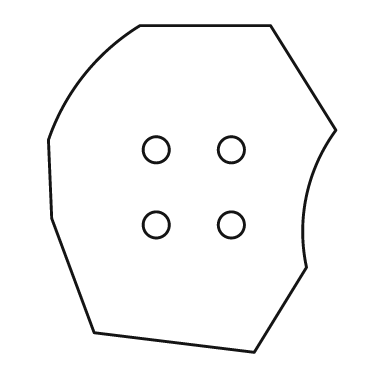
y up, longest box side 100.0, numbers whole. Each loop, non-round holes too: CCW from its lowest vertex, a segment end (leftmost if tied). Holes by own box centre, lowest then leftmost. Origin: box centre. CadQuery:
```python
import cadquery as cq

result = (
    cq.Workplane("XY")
    .moveTo(19.0, -50.0)
    .lineTo(35.0, -24.0)
    .threePointArc((35.0, -2.0), (44.0, 18.0))
    .lineTo(24.0, 50.0)
    .lineTo(-16.0, 50.0)
    .threePointArc((-33.0, 35.0), (-44.0, 15.0))
    .lineTo(-43.0, -9.0)
    .lineTo(-30.0, -44.0)
    .close()
    .moveTo(-11.0, -11.0)
    .circle(4.0)
    .moveTo(12.0, -11.0)
    .circle(4.0)
    .moveTo(-11.0, 12.0)
    .circle(4.0)
    .moveTo(12.0, 12.0)
    .circle(4.0)
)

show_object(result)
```